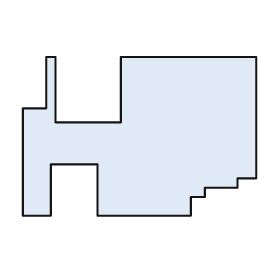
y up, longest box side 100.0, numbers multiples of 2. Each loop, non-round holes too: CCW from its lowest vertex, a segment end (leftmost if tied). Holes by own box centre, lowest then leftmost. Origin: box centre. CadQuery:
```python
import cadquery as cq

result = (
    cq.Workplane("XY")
    .moveTo(-50.0, -34.0)
    .lineTo(-38.0, -34.0)
    .lineTo(-38.0, -12.0)
    .lineTo(-18.0, -12.0)
    .lineTo(-18.0, -34.0)
    .lineTo(22.0, -34.0)
    .lineTo(22.0, -26.0)
    .lineTo(28.0, -26.0)
    .lineTo(28.0, -22.0)
    .lineTo(42.0, -22.0)
    .lineTo(42.0, -18.0)
    .lineTo(50.0, -18.0)
    .lineTo(50.0, 34.0)
    .lineTo(-8.0, 34.0)
    .lineTo(-8.0, 6.0)
    .lineTo(-36.0, 6.0)
    .lineTo(-36.0, 34.0)
    .lineTo(-40.0, 34.0)
    .lineTo(-40.0, 12.0)
    .lineTo(-50.0, 12.0)
    .close()
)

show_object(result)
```